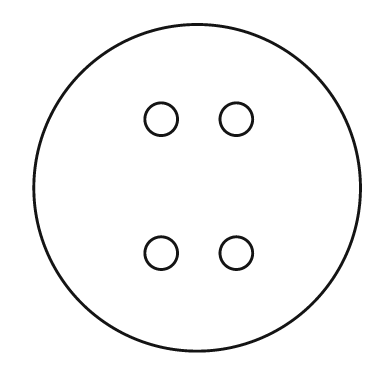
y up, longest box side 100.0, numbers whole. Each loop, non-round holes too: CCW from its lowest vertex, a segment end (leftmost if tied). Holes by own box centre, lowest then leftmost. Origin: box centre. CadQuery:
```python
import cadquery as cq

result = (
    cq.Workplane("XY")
    .moveTo(0.0, 0.0)
    .circle(50.0)
    .moveTo(-11.0, -20.0)
    .circle(5.0)
    .moveTo(12.0, -20.0)
    .circle(5.0)
    .moveTo(-11.0, 21.0)
    .circle(5.0)
    .moveTo(12.0, 21.0)
    .circle(5.0)
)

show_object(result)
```